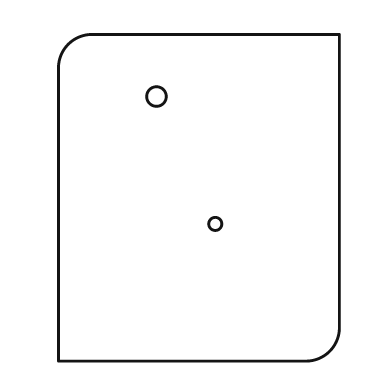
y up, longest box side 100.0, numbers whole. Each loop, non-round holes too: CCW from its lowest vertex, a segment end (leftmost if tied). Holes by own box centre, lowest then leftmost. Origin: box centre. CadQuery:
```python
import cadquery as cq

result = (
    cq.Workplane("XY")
    .moveTo(-43.0, -50.0)
    .lineTo(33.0, -50.0)
    .threePointArc((40.0, -47.0), (43.0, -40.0))
    .lineTo(43.0, 50.0)
    .lineTo(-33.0, 50.0)
    .threePointArc((-40.0, 47.0), (-43.0, 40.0))
    .close()
    .moveTo(5.0, -8.0)
    .circle(2.0)
    .moveTo(-13.0, 31.0)
    .circle(3.0)
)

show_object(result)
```